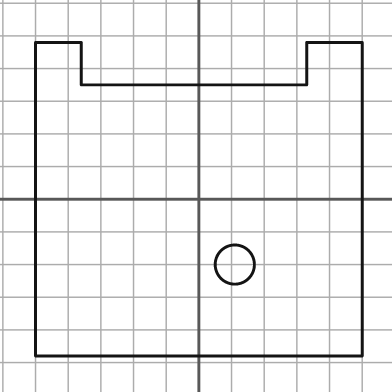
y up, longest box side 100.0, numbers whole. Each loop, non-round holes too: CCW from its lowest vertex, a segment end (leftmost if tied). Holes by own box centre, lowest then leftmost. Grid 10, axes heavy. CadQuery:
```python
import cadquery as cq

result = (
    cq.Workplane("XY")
    .moveTo(-50.0, -48.0)
    .lineTo(50.0, -48.0)
    .lineTo(50.0, 48.0)
    .lineTo(33.0, 48.0)
    .lineTo(33.0, 35.0)
    .lineTo(-36.0, 35.0)
    .lineTo(-36.0, 48.0)
    .lineTo(-50.0, 48.0)
    .close()
    .moveTo(11.0, -20.0)
    .circle(6.0)
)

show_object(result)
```